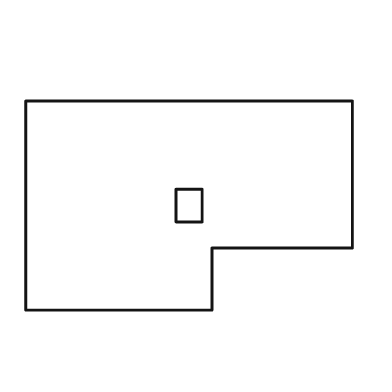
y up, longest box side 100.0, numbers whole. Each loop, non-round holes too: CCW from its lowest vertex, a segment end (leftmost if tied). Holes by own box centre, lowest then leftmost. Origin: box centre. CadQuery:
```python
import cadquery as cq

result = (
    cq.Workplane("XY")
    .moveTo(-50.0, -32.0)
    .lineTo(7.0, -32.0)
    .lineTo(7.0, -13.0)
    .lineTo(50.0, -13.0)
    .lineTo(50.0, 32.0)
    .lineTo(-50.0, 32.0)
    .close()
    .moveTo(-4.0, -5.0)
    .lineTo(4.0, -5.0)
    .lineTo(4.0, 5.0)
    .lineTo(-4.0, 5.0)
    .close()
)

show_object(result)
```